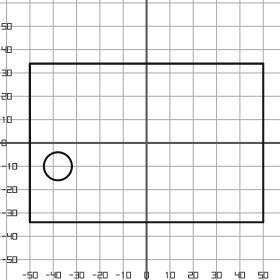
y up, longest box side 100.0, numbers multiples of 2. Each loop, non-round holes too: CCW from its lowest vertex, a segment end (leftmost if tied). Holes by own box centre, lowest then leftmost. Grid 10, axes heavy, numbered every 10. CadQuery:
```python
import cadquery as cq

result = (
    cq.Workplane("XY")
    .moveTo(-50.0, -34.0)
    .lineTo(50.0, -34.0)
    .lineTo(50.0, 34.0)
    .lineTo(-50.0, 34.0)
    .close()
    .moveTo(-38.0, -10.0)
    .circle(6.0)
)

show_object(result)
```